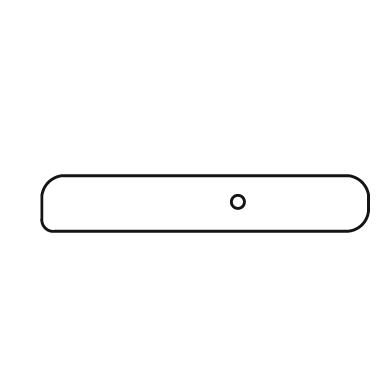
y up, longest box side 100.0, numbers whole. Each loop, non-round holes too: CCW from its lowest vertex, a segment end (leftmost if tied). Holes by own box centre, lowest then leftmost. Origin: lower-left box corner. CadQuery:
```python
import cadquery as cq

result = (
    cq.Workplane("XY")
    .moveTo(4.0, 0.0)
    .lineTo(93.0, 0.0)
    .threePointArc((98.0, 2.0), (100.0, 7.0))
    .lineTo(100.0, 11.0)
    .threePointArc((98.0, 15.0), (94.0, 17.0))
    .lineTo(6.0, 17.0)
    .threePointArc((2.0, 15.0), (0.0, 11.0))
    .lineTo(0.0, 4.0)
    .threePointArc((1.0, 1.0), (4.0, 0.0))
    .close()
    .moveTo(60.0, 9.0)
    .circle(2.0)
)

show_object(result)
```